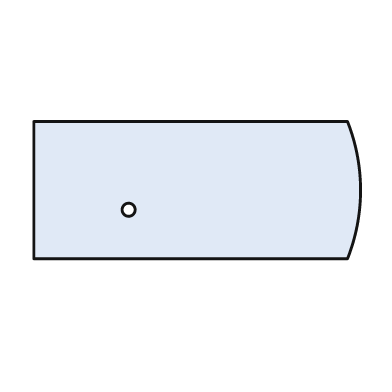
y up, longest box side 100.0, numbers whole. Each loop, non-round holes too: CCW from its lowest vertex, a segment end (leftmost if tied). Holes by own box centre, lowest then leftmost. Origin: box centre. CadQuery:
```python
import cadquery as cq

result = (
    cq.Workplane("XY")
    .moveTo(-50.0, -21.0)
    .lineTo(46.0, -21.0)
    .threePointArc((50.0, 0.0), (46.0, 21.0))
    .lineTo(-50.0, 21.0)
    .close()
    .moveTo(-21.0, -6.0)
    .circle(2.0)
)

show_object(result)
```